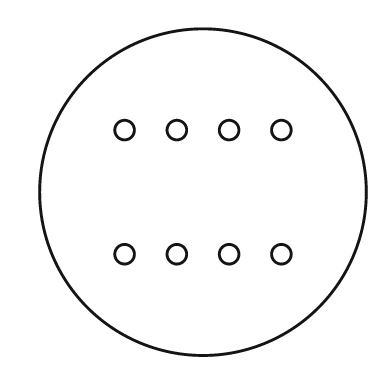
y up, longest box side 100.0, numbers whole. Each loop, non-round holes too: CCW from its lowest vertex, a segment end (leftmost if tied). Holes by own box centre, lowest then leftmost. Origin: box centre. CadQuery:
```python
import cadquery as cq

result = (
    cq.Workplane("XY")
    .moveTo(0.0, 0.0)
    .circle(50.0)
    .moveTo(-24.0, -19.0)
    .circle(3.0)
    .moveTo(-8.0, -19.0)
    .circle(3.0)
    .moveTo(8.0, -19.0)
    .circle(3.0)
    .moveTo(24.0, -19.0)
    .circle(3.0)
    .moveTo(-24.0, 19.0)
    .circle(3.0)
    .moveTo(-8.0, 19.0)
    .circle(3.0)
    .moveTo(8.0, 19.0)
    .circle(3.0)
    .moveTo(24.0, 19.0)
    .circle(3.0)
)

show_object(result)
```